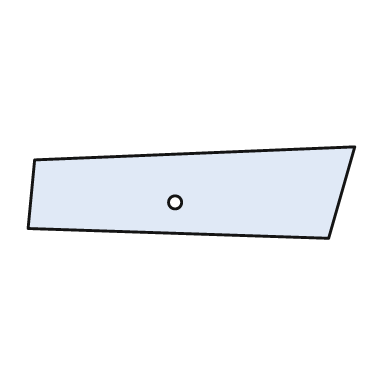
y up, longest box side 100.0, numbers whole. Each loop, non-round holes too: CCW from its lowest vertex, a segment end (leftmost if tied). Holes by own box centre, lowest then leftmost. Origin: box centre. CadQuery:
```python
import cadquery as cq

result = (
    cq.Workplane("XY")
    .moveTo(42.0, -14.0)
    .lineTo(50.0, 14.0)
    .lineTo(-48.0, 10.0)
    .lineTo(-50.0, -11.0)
    .close()
    .moveTo(-5.0, -3.0)
    .circle(2.0)
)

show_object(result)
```